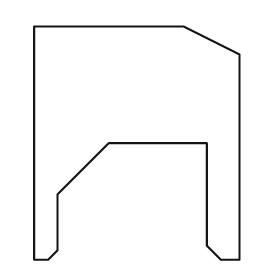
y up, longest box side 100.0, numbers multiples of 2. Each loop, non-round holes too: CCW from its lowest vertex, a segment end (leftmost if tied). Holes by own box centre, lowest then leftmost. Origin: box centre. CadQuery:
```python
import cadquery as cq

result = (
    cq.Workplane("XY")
    .moveTo(-44.0, -50.0)
    .lineTo(-38.0, -50.0)
    .lineTo(-34.0, -46.0)
    .lineTo(-34.0, -22.0)
    .lineTo(-12.0, 0.0)
    .lineTo(30.0, 0.0)
    .lineTo(30.0, -44.0)
    .lineTo(36.0, -50.0)
    .lineTo(44.0, -50.0)
    .lineTo(44.0, 38.0)
    .lineTo(20.0, 50.0)
    .lineTo(-44.0, 50.0)
    .close()
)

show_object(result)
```